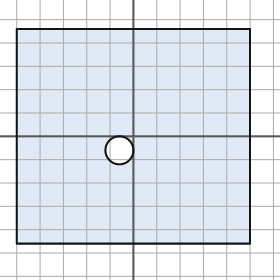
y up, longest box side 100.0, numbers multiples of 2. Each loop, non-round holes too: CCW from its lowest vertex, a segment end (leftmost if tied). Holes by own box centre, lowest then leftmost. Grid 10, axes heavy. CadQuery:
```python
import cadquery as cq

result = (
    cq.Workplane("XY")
    .moveTo(-50.0, -46.0)
    .lineTo(50.0, -46.0)
    .lineTo(50.0, 46.0)
    .lineTo(-50.0, 46.0)
    .close()
    .moveTo(-6.0, -6.0)
    .circle(6.0)
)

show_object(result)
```